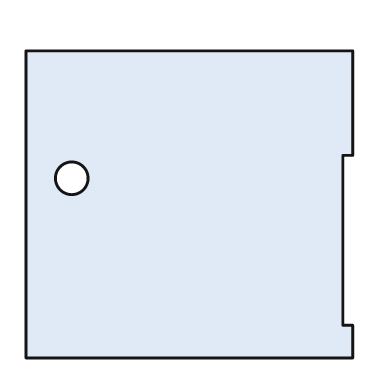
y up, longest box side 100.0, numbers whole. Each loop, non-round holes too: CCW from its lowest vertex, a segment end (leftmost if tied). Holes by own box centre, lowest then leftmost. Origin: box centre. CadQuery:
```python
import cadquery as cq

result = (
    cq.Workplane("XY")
    .moveTo(-50.0, -47.0)
    .lineTo(50.0, -47.0)
    .lineTo(50.0, -37.0)
    .lineTo(47.0, -37.0)
    .lineTo(47.0, 15.0)
    .lineTo(50.0, 15.0)
    .lineTo(50.0, 47.0)
    .lineTo(-50.0, 47.0)
    .close()
    .moveTo(-36.0, 8.0)
    .circle(5.0)
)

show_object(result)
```